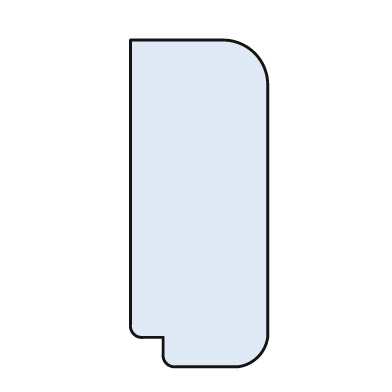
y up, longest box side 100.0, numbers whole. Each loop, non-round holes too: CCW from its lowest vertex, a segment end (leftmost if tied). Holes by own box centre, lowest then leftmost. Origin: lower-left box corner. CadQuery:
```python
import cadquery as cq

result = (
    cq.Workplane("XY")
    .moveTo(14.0, 0.0)
    .lineTo(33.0, 0.0)
    .threePointArc((39.0, 3.0), (42.0, 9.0))
    .lineTo(42.0, 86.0)
    .threePointArc((38.0, 96.0), (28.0, 100.0))
    .lineTo(0.0, 100.0)
    .lineTo(0.0, 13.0)
    .threePointArc((1.0, 10.0), (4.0, 9.0))
    .lineTo(10.0, 9.0)
    .lineTo(10.0, 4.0)
    .threePointArc((11.0, 1.0), (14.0, 0.0))
    .close()
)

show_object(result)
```